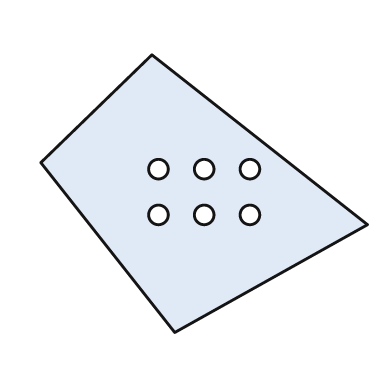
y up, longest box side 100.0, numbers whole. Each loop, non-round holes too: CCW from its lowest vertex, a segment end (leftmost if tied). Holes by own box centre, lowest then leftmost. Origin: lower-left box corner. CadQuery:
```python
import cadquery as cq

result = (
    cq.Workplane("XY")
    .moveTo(41.0, 0.0)
    .lineTo(100.0, 33.0)
    .lineTo(34.0, 85.0)
    .lineTo(0.0, 52.0)
    .close()
    .moveTo(36.0, 36.0)
    .circle(3.0)
    .moveTo(50.0, 36.0)
    .circle(3.0)
    .moveTo(64.0, 36.0)
    .circle(3.0)
    .moveTo(36.0, 50.0)
    .circle(3.0)
    .moveTo(50.0, 50.0)
    .circle(3.0)
    .moveTo(64.0, 50.0)
    .circle(3.0)
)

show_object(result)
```